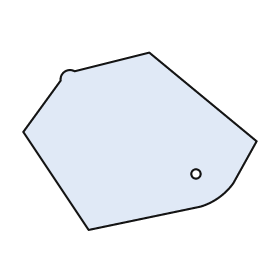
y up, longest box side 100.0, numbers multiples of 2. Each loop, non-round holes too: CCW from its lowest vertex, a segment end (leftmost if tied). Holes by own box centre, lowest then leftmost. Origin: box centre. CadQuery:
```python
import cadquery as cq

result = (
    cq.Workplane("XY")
    .moveTo(-22.0, -38.0)
    .lineTo(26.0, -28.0)
    .threePointArc((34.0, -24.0), (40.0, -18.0))
    .lineTo(50.0, 0.0)
    .lineTo(4.0, 38.0)
    .lineTo(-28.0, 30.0)
    .threePointArc((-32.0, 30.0), (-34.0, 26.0))
    .lineTo(-50.0, 4.0)
    .close()
    .moveTo(24.0, -14.0)
    .circle(2.0)
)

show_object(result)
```